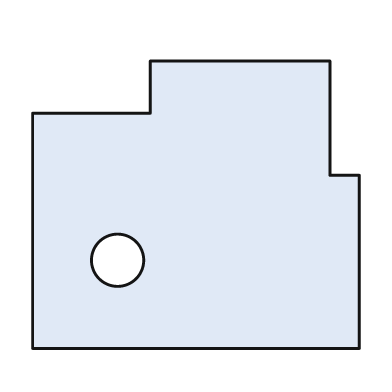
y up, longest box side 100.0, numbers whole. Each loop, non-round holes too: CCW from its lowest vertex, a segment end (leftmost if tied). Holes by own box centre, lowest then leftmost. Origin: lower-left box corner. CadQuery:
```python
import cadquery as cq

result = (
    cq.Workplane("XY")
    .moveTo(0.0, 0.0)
    .lineTo(100.0, 0.0)
    .lineTo(100.0, 53.0)
    .lineTo(91.0, 53.0)
    .lineTo(91.0, 88.0)
    .lineTo(36.0, 88.0)
    .lineTo(36.0, 72.0)
    .lineTo(0.0, 72.0)
    .close()
    .moveTo(26.0, 27.0)
    .circle(8.0)
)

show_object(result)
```